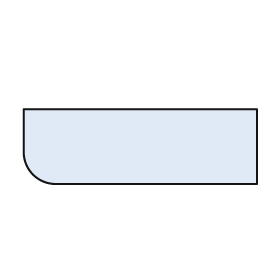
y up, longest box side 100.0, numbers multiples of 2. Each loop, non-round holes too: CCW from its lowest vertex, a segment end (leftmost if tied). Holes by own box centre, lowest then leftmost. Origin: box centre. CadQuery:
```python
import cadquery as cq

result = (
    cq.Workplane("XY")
    .moveTo(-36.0, -16.0)
    .lineTo(50.0, -16.0)
    .lineTo(50.0, 16.0)
    .lineTo(-50.0, 16.0)
    .lineTo(-50.0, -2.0)
    .threePointArc((-46.0, -12.0), (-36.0, -16.0))
    .close()
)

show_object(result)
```